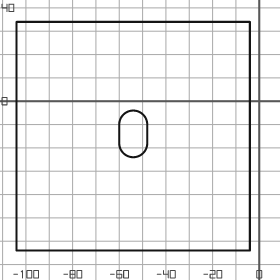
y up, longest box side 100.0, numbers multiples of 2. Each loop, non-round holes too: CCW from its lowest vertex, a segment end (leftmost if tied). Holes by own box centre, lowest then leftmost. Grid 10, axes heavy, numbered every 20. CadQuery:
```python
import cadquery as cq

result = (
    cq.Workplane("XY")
    .moveTo(-104.0, -64.0)
    .lineTo(-4.0, -64.0)
    .lineTo(-4.0, 34.0)
    .lineTo(-104.0, 34.0)
    .close()
    .moveTo(-60.0, -18.0)
    .threePointArc((-54.0, -24.0), (-48.0, -18.0))
    .lineTo(-48.0, -10.0)
    .threePointArc((-54.0, -4.0), (-60.0, -10.0))
    .close()
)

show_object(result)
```